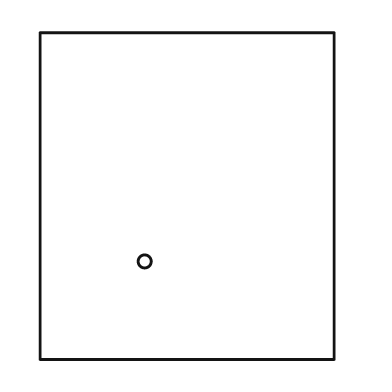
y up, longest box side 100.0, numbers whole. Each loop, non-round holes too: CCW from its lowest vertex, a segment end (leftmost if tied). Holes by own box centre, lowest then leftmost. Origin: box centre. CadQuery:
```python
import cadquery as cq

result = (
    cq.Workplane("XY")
    .moveTo(-45.0, -50.0)
    .lineTo(45.0, -50.0)
    .lineTo(45.0, 50.0)
    .lineTo(-45.0, 50.0)
    .close()
    .moveTo(-13.0, -20.0)
    .circle(2.0)
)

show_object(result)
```